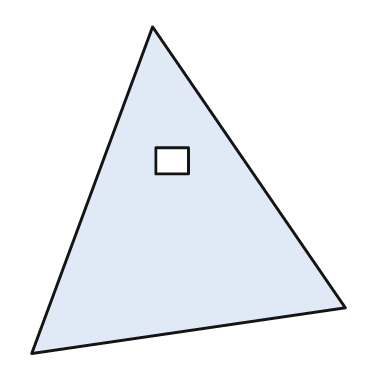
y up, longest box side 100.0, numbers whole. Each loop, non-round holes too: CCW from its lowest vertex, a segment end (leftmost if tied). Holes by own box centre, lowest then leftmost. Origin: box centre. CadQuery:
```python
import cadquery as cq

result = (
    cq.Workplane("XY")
    .moveTo(-48.0, -50.0)
    .lineTo(48.0, -36.0)
    .lineTo(-11.0, 50.0)
    .close()
    .moveTo(-10.0, 5.0)
    .lineTo(0.0, 5.0)
    .lineTo(0.0, 13.0)
    .lineTo(-10.0, 13.0)
    .close()
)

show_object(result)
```